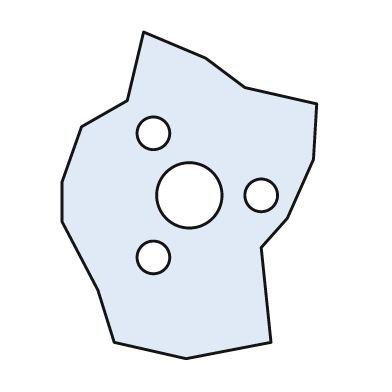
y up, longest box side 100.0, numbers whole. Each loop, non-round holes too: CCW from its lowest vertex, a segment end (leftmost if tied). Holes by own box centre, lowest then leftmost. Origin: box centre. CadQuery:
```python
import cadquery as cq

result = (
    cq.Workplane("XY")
    .moveTo(-1.0, -50.0)
    .lineTo(25.0, -45.0)
    .lineTo(22.0, -16.0)
    .lineTo(30.0, -7.0)
    .lineTo(38.0, 11.0)
    .lineTo(39.0, 28.0)
    .lineTo(17.0, 33.0)
    .lineTo(5.0, 42.0)
    .lineTo(-14.0, 50.0)
    .lineTo(-19.0, 29.0)
    .lineTo(-33.0, 21.0)
    .lineTo(-39.0, 4.0)
    .lineTo(-39.0, -8.0)
    .lineTo(-28.0, -29.0)
    .lineTo(-23.0, -45.0)
    .close()
    .moveTo(-11.0, -19.0)
    .circle(5.0)
    .moveTo(0.0, 0.0)
    .circle(10.0)
    .moveTo(22.0, 0.0)
    .circle(5.0)
    .moveTo(-11.0, 19.0)
    .circle(5.0)
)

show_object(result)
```